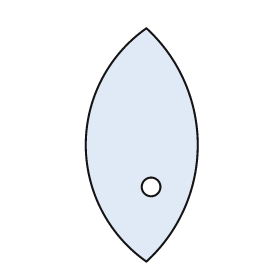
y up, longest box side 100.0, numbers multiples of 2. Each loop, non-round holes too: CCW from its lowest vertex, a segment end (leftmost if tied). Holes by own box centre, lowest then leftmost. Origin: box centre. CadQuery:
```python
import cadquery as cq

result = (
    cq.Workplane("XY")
    .moveTo(2.0, -50.0)
    .threePointArc((24.0, 0.0), (2.0, 50.0))
    .threePointArc((-24.0, 0.0), (2.0, -50.0))
    .close()
    .moveTo(4.0, -18.0)
    .circle(4.0)
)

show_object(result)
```